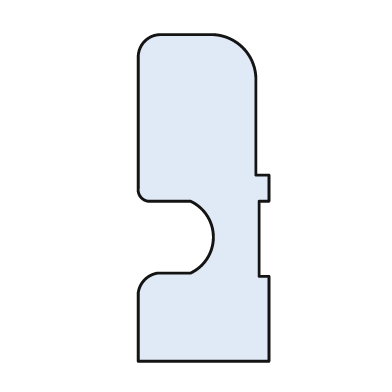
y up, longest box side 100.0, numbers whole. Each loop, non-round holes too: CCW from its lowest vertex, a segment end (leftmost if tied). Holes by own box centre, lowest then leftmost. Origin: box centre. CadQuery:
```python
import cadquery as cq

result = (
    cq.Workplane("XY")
    .moveTo(-20.0, -50.0)
    .lineTo(20.0, -50.0)
    .lineTo(20.0, -24.0)
    .lineTo(17.0, -24.0)
    .lineTo(17.0, -1.0)
    .lineTo(20.0, -1.0)
    .lineTo(20.0, 7.0)
    .lineTo(16.0, 7.0)
    .lineTo(16.0, 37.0)
    .threePointArc((12.0, 46.0), (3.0, 50.0))
    .lineTo(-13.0, 50.0)
    .threePointArc((-18.0, 48.0), (-20.0, 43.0))
    .lineTo(-20.0, 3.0)
    .threePointArc((-19.0, 0.0), (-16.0, -1.0))
    .lineTo(-4.0, -1.0)
    .threePointArc((3.0, -12.0), (-4.0, -23.0))
    .lineTo(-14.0, -23.0)
    .threePointArc((-18.0, -25.0), (-20.0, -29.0))
    .close()
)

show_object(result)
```